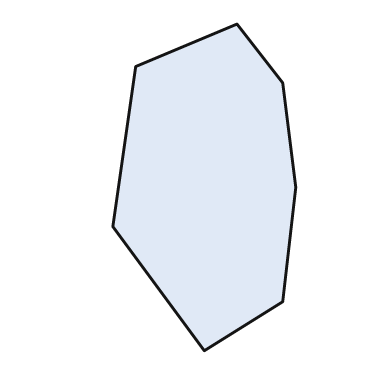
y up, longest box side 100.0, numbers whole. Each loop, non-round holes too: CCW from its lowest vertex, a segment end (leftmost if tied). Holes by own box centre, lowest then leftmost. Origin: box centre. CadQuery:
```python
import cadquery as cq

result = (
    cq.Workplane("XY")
    .moveTo(0.0, -50.0)
    .lineTo(24.0, -35.0)
    .lineTo(28.0, 0.0)
    .lineTo(24.0, 32.0)
    .lineTo(10.0, 50.0)
    .lineTo(-21.0, 37.0)
    .lineTo(-28.0, -12.0)
    .close()
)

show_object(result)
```